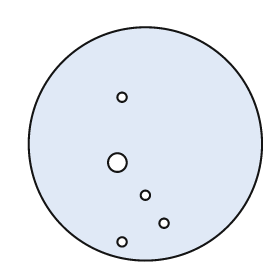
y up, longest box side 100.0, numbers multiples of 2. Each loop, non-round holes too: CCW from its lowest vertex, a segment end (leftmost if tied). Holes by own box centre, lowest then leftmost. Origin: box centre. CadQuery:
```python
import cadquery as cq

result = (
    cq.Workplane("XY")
    .moveTo(0.0, 0.0)
    .circle(50.0)
    .moveTo(-10.0, -42.0)
    .circle(2.0)
    .moveTo(8.0, -34.0)
    .circle(2.0)
    .moveTo(0.0, -22.0)
    .circle(2.0)
    .moveTo(-12.0, -8.0)
    .circle(4.0)
    .moveTo(-10.0, 20.0)
    .circle(2.0)
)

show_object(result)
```